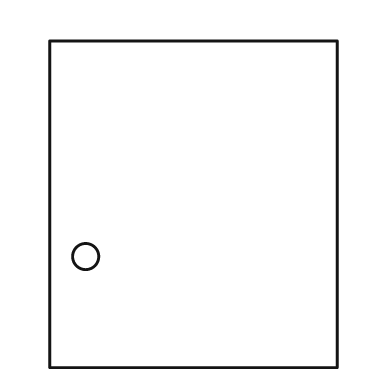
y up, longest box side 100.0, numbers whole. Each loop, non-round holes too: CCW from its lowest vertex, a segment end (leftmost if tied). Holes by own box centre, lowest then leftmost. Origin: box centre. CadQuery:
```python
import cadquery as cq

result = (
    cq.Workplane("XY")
    .moveTo(-44.0, -50.0)
    .lineTo(44.0, -50.0)
    .lineTo(44.0, 50.0)
    .lineTo(-44.0, 50.0)
    .close()
    .moveTo(-33.0, -16.0)
    .circle(4.0)
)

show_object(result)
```